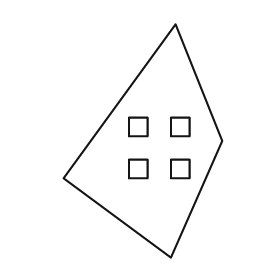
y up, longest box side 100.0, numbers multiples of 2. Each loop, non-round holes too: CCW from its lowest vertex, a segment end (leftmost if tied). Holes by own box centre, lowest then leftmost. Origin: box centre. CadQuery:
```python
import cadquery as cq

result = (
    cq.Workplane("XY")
    .moveTo(12.0, -50.0)
    .lineTo(34.0, 0.0)
    .lineTo(14.0, 50.0)
    .lineTo(-34.0, -16.0)
    .close()
    .moveTo(-6.0, -16.0)
    .lineTo(2.0, -16.0)
    .lineTo(2.0, -8.0)
    .lineTo(-6.0, -8.0)
    .close()
    .moveTo(12.0, -16.0)
    .lineTo(20.0, -16.0)
    .lineTo(20.0, -8.0)
    .lineTo(12.0, -8.0)
    .close()
    .moveTo(-6.0, 2.0)
    .lineTo(2.0, 2.0)
    .lineTo(2.0, 10.0)
    .lineTo(-6.0, 10.0)
    .close()
    .moveTo(12.0, 2.0)
    .lineTo(20.0, 2.0)
    .lineTo(20.0, 10.0)
    .lineTo(12.0, 10.0)
    .close()
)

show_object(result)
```